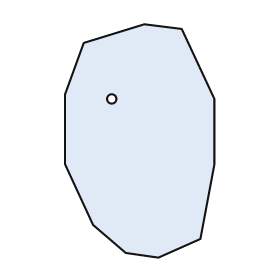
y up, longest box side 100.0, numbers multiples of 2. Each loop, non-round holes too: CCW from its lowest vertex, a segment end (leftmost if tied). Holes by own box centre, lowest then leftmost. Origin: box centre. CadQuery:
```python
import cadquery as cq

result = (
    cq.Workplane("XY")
    .moveTo(8.0, -50.0)
    .lineTo(26.0, -42.0)
    .lineTo(32.0, -10.0)
    .lineTo(32.0, 18.0)
    .lineTo(18.0, 48.0)
    .lineTo(2.0, 50.0)
    .lineTo(-24.0, 42.0)
    .lineTo(-32.0, 20.0)
    .lineTo(-32.0, -10.0)
    .lineTo(-20.0, -36.0)
    .lineTo(-6.0, -48.0)
    .close()
    .moveTo(-12.0, 18.0)
    .circle(2.0)
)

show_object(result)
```